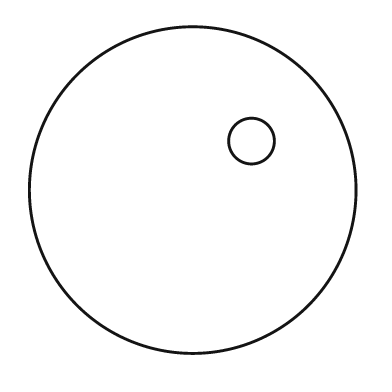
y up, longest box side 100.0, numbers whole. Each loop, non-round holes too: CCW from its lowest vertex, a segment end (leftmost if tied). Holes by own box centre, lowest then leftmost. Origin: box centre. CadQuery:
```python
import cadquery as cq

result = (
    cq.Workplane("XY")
    .moveTo(0.0, 0.0)
    .circle(50.0)
    .moveTo(18.0, 15.0)
    .circle(7.0)
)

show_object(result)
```